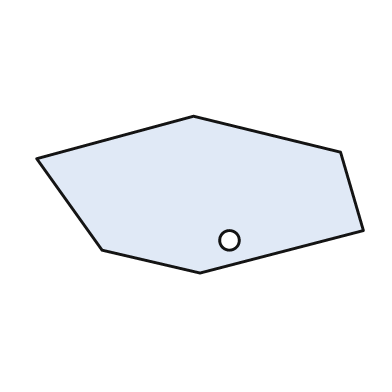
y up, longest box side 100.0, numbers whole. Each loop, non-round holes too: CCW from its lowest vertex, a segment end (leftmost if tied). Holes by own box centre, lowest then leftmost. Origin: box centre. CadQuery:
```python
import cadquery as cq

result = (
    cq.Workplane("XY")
    .moveTo(0.0, -24.0)
    .lineTo(50.0, -11.0)
    .lineTo(43.0, 13.0)
    .lineTo(-2.0, 24.0)
    .lineTo(-50.0, 11.0)
    .lineTo(-30.0, -17.0)
    .close()
    .moveTo(9.0, -14.0)
    .circle(3.0)
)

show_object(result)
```